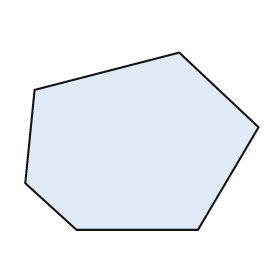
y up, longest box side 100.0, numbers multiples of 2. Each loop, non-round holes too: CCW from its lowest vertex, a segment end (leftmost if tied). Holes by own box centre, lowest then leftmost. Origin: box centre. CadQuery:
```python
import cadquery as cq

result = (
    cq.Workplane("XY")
    .moveTo(-28.0, -38.0)
    .lineTo(24.0, -38.0)
    .lineTo(50.0, 6.0)
    .lineTo(16.0, 38.0)
    .lineTo(-46.0, 22.0)
    .lineTo(-50.0, -18.0)
    .close()
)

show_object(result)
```